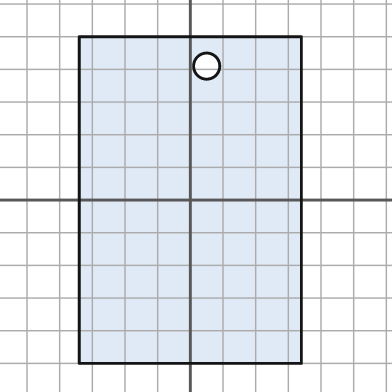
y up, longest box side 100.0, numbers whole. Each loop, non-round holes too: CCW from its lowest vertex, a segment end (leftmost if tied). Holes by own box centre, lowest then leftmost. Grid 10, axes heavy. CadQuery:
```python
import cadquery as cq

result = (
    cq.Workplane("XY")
    .moveTo(-34.0, -50.0)
    .lineTo(34.0, -50.0)
    .lineTo(34.0, 50.0)
    .lineTo(-34.0, 50.0)
    .close()
    .moveTo(5.0, 41.0)
    .circle(4.0)
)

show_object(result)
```